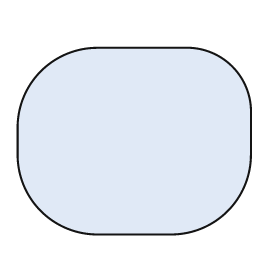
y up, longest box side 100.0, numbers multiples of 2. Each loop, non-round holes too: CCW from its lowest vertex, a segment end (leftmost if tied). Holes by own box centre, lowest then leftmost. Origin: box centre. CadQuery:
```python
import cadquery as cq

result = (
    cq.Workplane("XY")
    .moveTo(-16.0, -40.0)
    .lineTo(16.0, -40.0)
    .threePointArc((40.0, -30.0), (50.0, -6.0))
    .lineTo(50.0, 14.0)
    .threePointArc((42.0, 32.0), (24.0, 40.0))
    .lineTo(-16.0, 40.0)
    .threePointArc((-40.0, 30.0), (-50.0, 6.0))
    .lineTo(-50.0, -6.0)
    .threePointArc((-40.0, -30.0), (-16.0, -40.0))
    .close()
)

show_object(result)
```